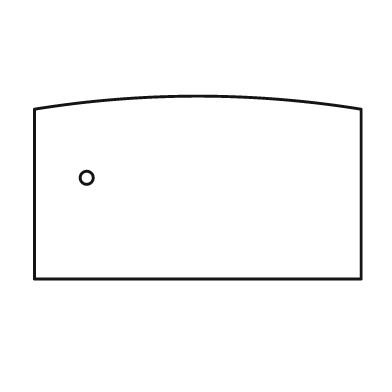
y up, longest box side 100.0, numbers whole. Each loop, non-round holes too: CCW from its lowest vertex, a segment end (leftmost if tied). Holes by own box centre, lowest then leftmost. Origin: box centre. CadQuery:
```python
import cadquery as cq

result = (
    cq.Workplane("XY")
    .moveTo(-50.0, -28.0)
    .lineTo(50.0, -28.0)
    .lineTo(50.0, 24.0)
    .threePointArc((0.0, 28.0), (-50.0, 24.0))
    .close()
    .moveTo(-34.0, 3.0)
    .circle(2.0)
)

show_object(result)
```